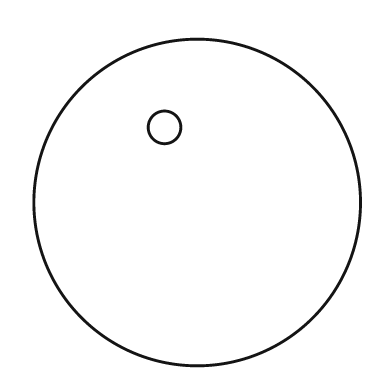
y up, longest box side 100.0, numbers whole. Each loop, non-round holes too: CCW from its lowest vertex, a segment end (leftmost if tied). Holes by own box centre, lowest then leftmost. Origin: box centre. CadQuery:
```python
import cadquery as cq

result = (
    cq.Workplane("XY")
    .moveTo(0.0, 0.0)
    .circle(50.0)
    .moveTo(-10.0, 23.0)
    .circle(5.0)
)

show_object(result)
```